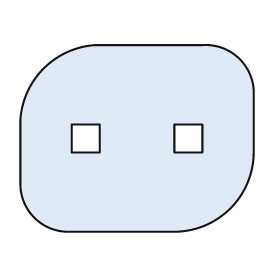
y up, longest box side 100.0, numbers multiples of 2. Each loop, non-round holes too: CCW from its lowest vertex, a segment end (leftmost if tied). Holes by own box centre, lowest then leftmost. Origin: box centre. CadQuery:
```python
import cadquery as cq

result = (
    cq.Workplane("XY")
    .moveTo(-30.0, -40.0)
    .lineTo(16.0, -40.0)
    .threePointArc((40.0, -30.0), (50.0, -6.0))
    .lineTo(50.0, 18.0)
    .threePointArc((44.0, 34.0), (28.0, 40.0))
    .lineTo(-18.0, 40.0)
    .threePointArc((-40.0, 30.0), (-50.0, 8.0))
    .lineTo(-50.0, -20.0)
    .threePointArc((-44.0, -34.0), (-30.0, -40.0))
    .close()
    .moveTo(-28.0, -6.0)
    .lineTo(-16.0, -6.0)
    .lineTo(-16.0, 6.0)
    .lineTo(-28.0, 6.0)
    .close()
    .moveTo(16.0, -6.0)
    .lineTo(28.0, -6.0)
    .lineTo(28.0, 6.0)
    .lineTo(16.0, 6.0)
    .close()
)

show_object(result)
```